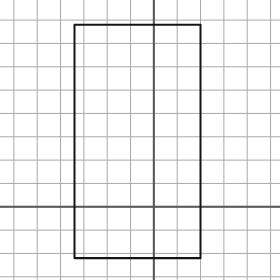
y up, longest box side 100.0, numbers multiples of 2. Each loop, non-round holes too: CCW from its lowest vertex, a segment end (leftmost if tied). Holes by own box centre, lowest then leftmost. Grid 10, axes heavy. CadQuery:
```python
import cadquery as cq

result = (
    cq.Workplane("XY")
    .moveTo(-34.0, -22.0)
    .lineTo(20.0, -22.0)
    .lineTo(20.0, 78.0)
    .lineTo(-34.0, 78.0)
    .close()
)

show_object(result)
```